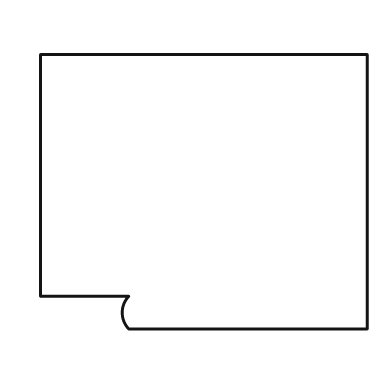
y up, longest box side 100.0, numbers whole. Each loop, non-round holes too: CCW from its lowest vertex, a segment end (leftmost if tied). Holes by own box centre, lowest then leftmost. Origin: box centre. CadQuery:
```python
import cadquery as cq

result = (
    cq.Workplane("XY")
    .moveTo(-23.0, -42.0)
    .lineTo(50.0, -42.0)
    .lineTo(50.0, 42.0)
    .lineTo(-50.0, 42.0)
    .lineTo(-50.0, -32.0)
    .lineTo(-23.0, -32.0)
    .threePointArc((-25.0, -37.0), (-23.0, -42.0))
    .close()
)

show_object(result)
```